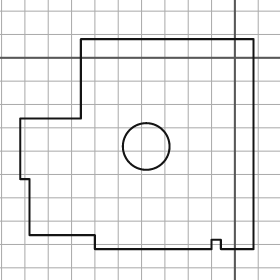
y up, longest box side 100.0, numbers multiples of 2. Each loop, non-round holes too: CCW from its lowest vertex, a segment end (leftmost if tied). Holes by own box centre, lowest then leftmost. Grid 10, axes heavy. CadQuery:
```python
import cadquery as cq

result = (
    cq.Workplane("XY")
    .moveTo(-60.0, -82.0)
    .lineTo(-10.0, -82.0)
    .lineTo(-10.0, -78.0)
    .lineTo(-6.0, -78.0)
    .lineTo(-6.0, -82.0)
    .lineTo(8.0, -82.0)
    .lineTo(8.0, 8.0)
    .lineTo(-66.0, 8.0)
    .lineTo(-66.0, -26.0)
    .lineTo(-92.0, -26.0)
    .lineTo(-92.0, -52.0)
    .lineTo(-88.0, -52.0)
    .lineTo(-88.0, -76.0)
    .lineTo(-60.0, -76.0)
    .close()
    .moveTo(-38.0, -38.0)
    .circle(10.0)
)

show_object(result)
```